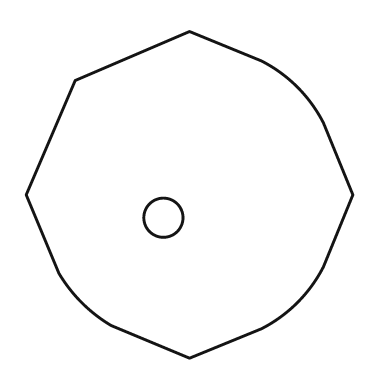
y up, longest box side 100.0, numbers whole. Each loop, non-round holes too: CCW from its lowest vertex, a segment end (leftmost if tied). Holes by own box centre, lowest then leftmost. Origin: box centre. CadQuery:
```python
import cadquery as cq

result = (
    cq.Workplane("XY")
    .moveTo(0.0, -50.0)
    .lineTo(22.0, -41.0)
    .threePointArc((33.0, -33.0), (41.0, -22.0))
    .lineTo(50.0, 0.0)
    .lineTo(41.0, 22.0)
    .threePointArc((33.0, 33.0), (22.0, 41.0))
    .lineTo(0.0, 50.0)
    .lineTo(-35.0, 35.0)
    .lineTo(-50.0, 0.0)
    .lineTo(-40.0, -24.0)
    .threePointArc((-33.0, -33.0), (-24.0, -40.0))
    .close()
    .moveTo(-8.0, -7.0)
    .circle(6.0)
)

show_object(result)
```